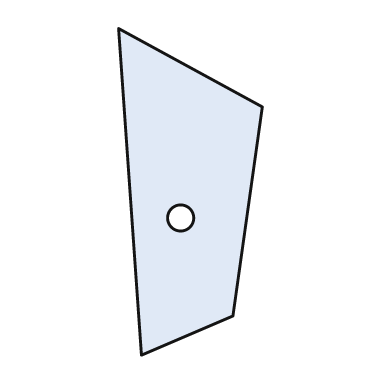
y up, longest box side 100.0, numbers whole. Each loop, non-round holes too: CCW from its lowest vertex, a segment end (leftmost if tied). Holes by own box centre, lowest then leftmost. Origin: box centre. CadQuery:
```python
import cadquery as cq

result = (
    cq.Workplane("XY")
    .moveTo(-15.0, -50.0)
    .lineTo(13.0, -38.0)
    .lineTo(22.0, 26.0)
    .lineTo(-22.0, 50.0)
    .close()
    .moveTo(-3.0, -8.0)
    .circle(4.0)
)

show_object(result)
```